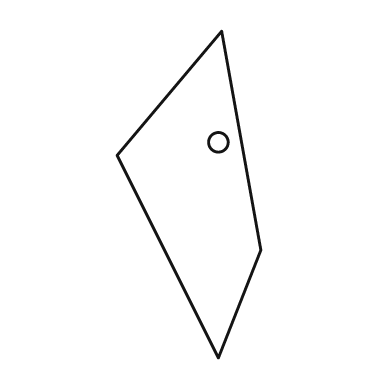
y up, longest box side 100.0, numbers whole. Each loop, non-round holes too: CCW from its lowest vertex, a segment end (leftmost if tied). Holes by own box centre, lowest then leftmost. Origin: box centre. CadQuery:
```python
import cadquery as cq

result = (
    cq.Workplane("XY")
    .moveTo(9.0, -50.0)
    .lineTo(22.0, -17.0)
    .lineTo(10.0, 50.0)
    .lineTo(-22.0, 12.0)
    .close()
    .moveTo(9.0, 16.0)
    .circle(3.0)
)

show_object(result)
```